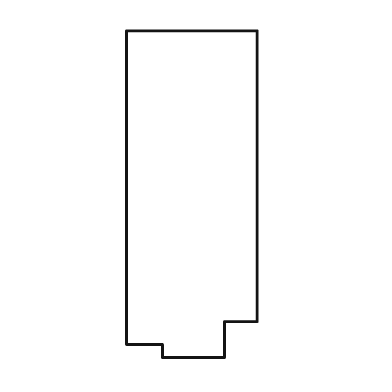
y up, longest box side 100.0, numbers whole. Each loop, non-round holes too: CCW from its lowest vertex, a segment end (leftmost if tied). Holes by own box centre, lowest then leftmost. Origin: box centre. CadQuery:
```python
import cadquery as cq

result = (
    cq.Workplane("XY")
    .moveTo(-9.0, -50.0)
    .lineTo(10.0, -50.0)
    .lineTo(10.0, -39.0)
    .lineTo(20.0, -39.0)
    .lineTo(20.0, 50.0)
    .lineTo(-20.0, 50.0)
    .lineTo(-20.0, -46.0)
    .lineTo(-9.0, -46.0)
    .close()
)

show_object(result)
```